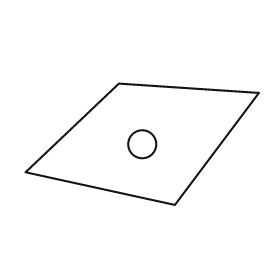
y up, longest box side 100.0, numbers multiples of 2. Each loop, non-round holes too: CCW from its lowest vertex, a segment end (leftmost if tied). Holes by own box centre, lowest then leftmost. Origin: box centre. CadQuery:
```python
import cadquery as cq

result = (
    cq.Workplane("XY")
    .moveTo(14.0, -26.0)
    .lineTo(50.0, 22.0)
    .lineTo(-10.0, 26.0)
    .lineTo(-50.0, -12.0)
    .close()
    .moveTo(0.0, 0.0)
    .circle(6.0)
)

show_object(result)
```